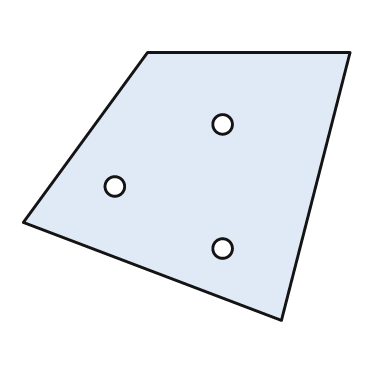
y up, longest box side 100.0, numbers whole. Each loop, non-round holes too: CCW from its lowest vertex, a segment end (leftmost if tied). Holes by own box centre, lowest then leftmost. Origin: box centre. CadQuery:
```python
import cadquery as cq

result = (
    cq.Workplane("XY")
    .moveTo(29.0, -41.0)
    .lineTo(50.0, 41.0)
    .lineTo(-12.0, 41.0)
    .lineTo(-50.0, -11.0)
    .close()
    .moveTo(11.0, -19.0)
    .circle(3.0)
    .moveTo(-22.0, 0.0)
    .circle(3.0)
    .moveTo(11.0, 19.0)
    .circle(3.0)
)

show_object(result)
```